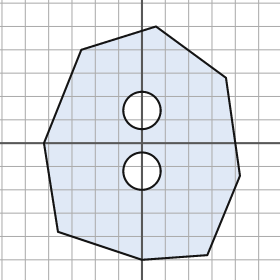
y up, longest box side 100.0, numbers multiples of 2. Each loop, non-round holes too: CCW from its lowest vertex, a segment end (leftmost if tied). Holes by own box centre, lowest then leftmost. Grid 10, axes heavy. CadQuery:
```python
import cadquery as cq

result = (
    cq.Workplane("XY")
    .moveTo(0.0, -50.0)
    .lineTo(28.0, -48.0)
    .lineTo(42.0, -14.0)
    .lineTo(36.0, 28.0)
    .lineTo(6.0, 50.0)
    .lineTo(-26.0, 40.0)
    .lineTo(-42.0, 0.0)
    .lineTo(-36.0, -38.0)
    .close()
    .moveTo(0.0, -12.0)
    .circle(8.0)
    .moveTo(0.0, 14.0)
    .circle(8.0)
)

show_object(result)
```